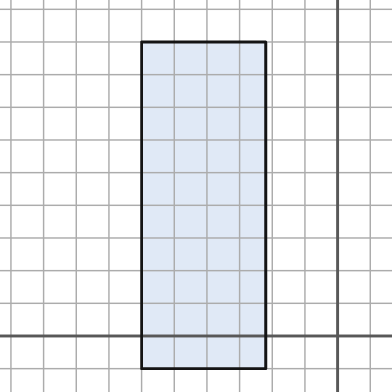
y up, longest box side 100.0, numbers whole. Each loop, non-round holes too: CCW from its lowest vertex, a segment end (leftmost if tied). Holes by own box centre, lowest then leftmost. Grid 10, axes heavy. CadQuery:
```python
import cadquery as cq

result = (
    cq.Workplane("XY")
    .moveTo(-60.0, -10.0)
    .lineTo(-22.0, -10.0)
    .lineTo(-22.0, 90.0)
    .lineTo(-60.0, 90.0)
    .close()
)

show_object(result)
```